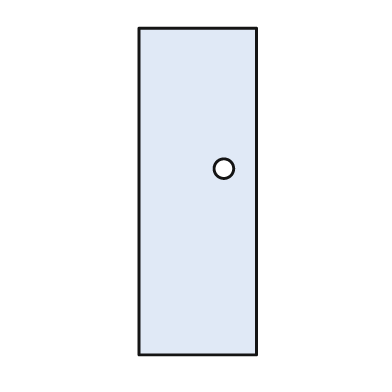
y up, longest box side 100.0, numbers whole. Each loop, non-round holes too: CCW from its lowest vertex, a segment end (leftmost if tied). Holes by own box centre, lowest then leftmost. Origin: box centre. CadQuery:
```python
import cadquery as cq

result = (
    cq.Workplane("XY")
    .moveTo(-18.0, -50.0)
    .lineTo(18.0, -50.0)
    .lineTo(18.0, 50.0)
    .lineTo(-18.0, 50.0)
    .close()
    .moveTo(8.0, 7.0)
    .circle(3.0)
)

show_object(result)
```